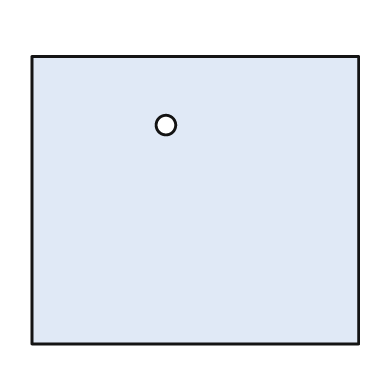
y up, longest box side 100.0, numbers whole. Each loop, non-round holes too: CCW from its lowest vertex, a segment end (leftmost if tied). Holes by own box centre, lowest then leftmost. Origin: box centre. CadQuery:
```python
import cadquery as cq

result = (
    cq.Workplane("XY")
    .moveTo(-50.0, -44.0)
    .lineTo(50.0, -44.0)
    .lineTo(50.0, 44.0)
    .lineTo(-50.0, 44.0)
    .close()
    .moveTo(-9.0, 23.0)
    .circle(3.0)
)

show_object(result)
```